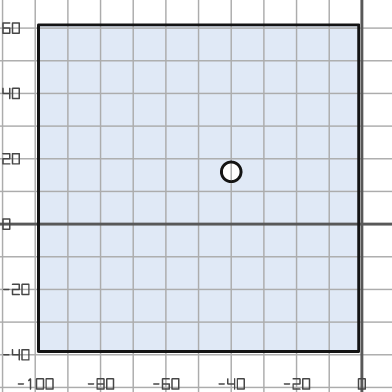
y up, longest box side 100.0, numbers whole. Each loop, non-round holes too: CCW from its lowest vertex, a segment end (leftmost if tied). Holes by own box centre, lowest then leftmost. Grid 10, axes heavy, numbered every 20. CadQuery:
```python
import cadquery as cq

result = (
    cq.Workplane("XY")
    .moveTo(-99.0, -39.0)
    .lineTo(-1.0, -39.0)
    .lineTo(-1.0, 61.0)
    .lineTo(-99.0, 61.0)
    .close()
    .moveTo(-40.0, 16.0)
    .circle(3.0)
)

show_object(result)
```